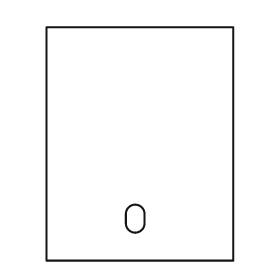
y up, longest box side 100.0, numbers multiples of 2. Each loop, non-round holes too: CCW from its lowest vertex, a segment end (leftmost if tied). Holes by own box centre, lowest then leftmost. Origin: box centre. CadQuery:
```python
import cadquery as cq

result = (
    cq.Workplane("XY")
    .moveTo(-40.0, -50.0)
    .lineTo(40.0, -50.0)
    .lineTo(40.0, 50.0)
    .lineTo(-40.0, 50.0)
    .close()
    .moveTo(-6.0, -34.0)
    .threePointArc((-2.0, -38.0), (2.0, -34.0))
    .lineTo(2.0, -30.0)
    .threePointArc((-2.0, -26.0), (-6.0, -30.0))
    .close()
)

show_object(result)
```